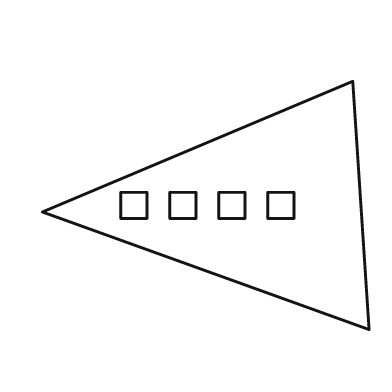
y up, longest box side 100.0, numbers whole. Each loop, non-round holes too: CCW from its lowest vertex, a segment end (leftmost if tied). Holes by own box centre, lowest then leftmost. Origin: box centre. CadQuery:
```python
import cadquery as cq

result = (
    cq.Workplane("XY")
    .moveTo(50.0, -38.0)
    .lineTo(45.0, 38.0)
    .lineTo(-50.0, -2.0)
    .close()
    .moveTo(-26.0, -4.0)
    .lineTo(-18.0, -4.0)
    .lineTo(-18.0, 4.0)
    .lineTo(-26.0, 4.0)
    .close()
    .moveTo(-11.0, -4.0)
    .lineTo(-3.0, -4.0)
    .lineTo(-3.0, 4.0)
    .lineTo(-11.0, 4.0)
    .close()
    .moveTo(4.0, -4.0)
    .lineTo(12.0, -4.0)
    .lineTo(12.0, 4.0)
    .lineTo(4.0, 4.0)
    .close()
    .moveTo(19.0, -4.0)
    .lineTo(27.0, -4.0)
    .lineTo(27.0, 4.0)
    .lineTo(19.0, 4.0)
    .close()
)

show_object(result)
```